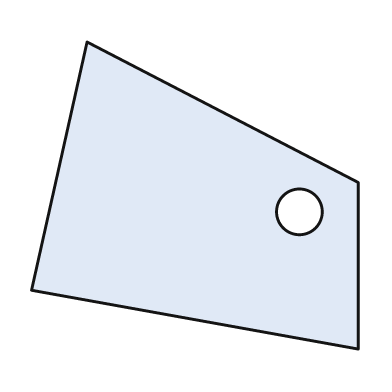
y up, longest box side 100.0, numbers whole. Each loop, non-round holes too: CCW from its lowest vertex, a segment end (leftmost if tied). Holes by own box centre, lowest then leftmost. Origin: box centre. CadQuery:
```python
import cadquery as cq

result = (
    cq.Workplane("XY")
    .moveTo(50.0, -47.0)
    .lineTo(50.0, 4.0)
    .lineTo(-33.0, 47.0)
    .lineTo(-50.0, -29.0)
    .close()
    .moveTo(32.0, -5.0)
    .circle(7.0)
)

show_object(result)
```